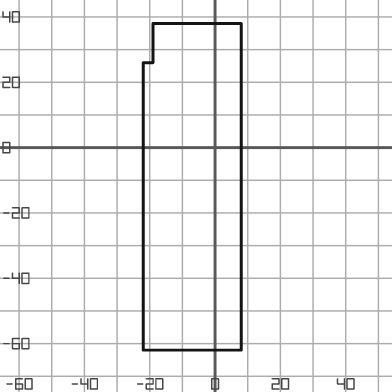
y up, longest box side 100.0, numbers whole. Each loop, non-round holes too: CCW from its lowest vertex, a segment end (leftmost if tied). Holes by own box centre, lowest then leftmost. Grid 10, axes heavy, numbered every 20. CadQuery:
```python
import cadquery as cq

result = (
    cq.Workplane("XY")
    .moveTo(-22.0, -62.0)
    .lineTo(8.0, -62.0)
    .lineTo(8.0, 38.0)
    .lineTo(-19.0, 38.0)
    .lineTo(-19.0, 26.0)
    .lineTo(-22.0, 26.0)
    .close()
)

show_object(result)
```